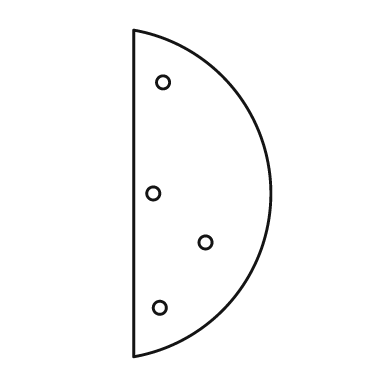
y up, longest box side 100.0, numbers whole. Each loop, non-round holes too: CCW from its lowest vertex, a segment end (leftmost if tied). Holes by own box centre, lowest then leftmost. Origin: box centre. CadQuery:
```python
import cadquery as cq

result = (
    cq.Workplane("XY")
    .moveTo(-21.0, -50.0)
    .threePointArc((21.0, 0.0), (-21.0, 50.0))
    .close()
    .moveTo(-13.0, -35.0)
    .circle(2.0)
    .moveTo(1.0, -15.0)
    .circle(2.0)
    .moveTo(-15.0, 0.0)
    .circle(2.0)
    .moveTo(-12.0, 34.0)
    .circle(2.0)
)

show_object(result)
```